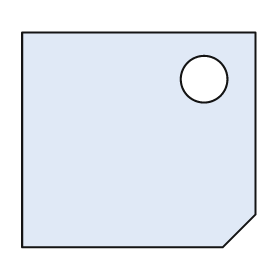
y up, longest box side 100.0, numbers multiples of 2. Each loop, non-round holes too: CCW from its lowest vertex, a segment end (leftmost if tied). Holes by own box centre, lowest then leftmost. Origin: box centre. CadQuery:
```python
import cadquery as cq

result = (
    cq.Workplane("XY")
    .moveTo(-50.0, -46.0)
    .lineTo(36.0, -46.0)
    .lineTo(50.0, -32.0)
    .lineTo(50.0, 46.0)
    .lineTo(-50.0, 46.0)
    .close()
    .moveTo(28.0, 26.0)
    .circle(10.0)
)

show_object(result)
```